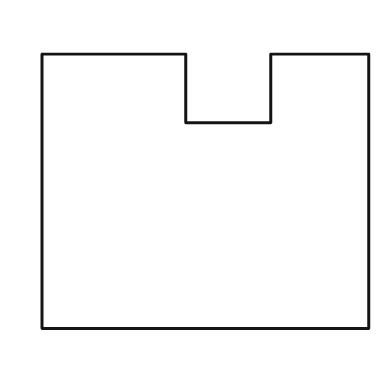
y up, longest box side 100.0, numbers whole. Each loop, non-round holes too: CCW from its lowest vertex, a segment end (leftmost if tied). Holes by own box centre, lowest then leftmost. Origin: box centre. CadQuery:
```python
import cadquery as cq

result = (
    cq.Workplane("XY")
    .moveTo(-50.0, -42.0)
    .lineTo(50.0, -42.0)
    .lineTo(50.0, 42.0)
    .lineTo(20.0, 42.0)
    .lineTo(20.0, 21.0)
    .lineTo(-6.0, 21.0)
    .lineTo(-6.0, 42.0)
    .lineTo(-50.0, 42.0)
    .close()
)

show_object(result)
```